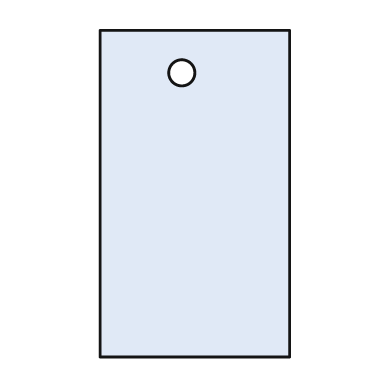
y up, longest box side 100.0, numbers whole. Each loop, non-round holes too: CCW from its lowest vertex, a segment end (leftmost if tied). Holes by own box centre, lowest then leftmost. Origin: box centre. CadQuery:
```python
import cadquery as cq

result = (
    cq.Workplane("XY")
    .moveTo(-29.0, -50.0)
    .lineTo(29.0, -50.0)
    .lineTo(29.0, 50.0)
    .lineTo(-29.0, 50.0)
    .close()
    .moveTo(-4.0, 37.0)
    .circle(4.0)
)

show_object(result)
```